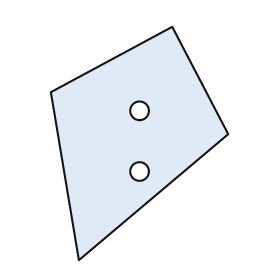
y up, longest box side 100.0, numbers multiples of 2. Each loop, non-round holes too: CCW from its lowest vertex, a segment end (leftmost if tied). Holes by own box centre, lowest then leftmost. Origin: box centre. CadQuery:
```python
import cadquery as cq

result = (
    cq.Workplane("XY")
    .moveTo(-26.0, -50.0)
    .lineTo(38.0, 4.0)
    .lineTo(14.0, 50.0)
    .lineTo(-38.0, 22.0)
    .close()
    .moveTo(0.0, -12.0)
    .circle(4.0)
    .moveTo(0.0, 14.0)
    .circle(4.0)
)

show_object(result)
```